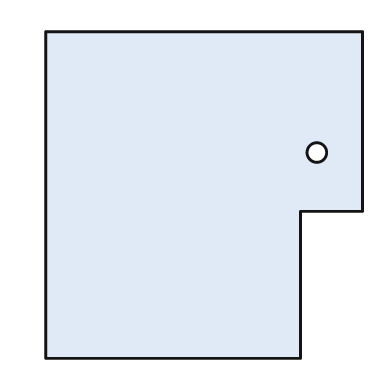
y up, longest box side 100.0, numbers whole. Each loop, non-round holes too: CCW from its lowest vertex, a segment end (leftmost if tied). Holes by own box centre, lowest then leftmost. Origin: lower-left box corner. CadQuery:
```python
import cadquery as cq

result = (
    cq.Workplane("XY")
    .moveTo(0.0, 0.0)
    .lineTo(78.0, 0.0)
    .lineTo(78.0, 45.0)
    .lineTo(97.0, 45.0)
    .lineTo(97.0, 100.0)
    .lineTo(0.0, 100.0)
    .close()
    .moveTo(83.0, 63.0)
    .circle(3.0)
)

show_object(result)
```